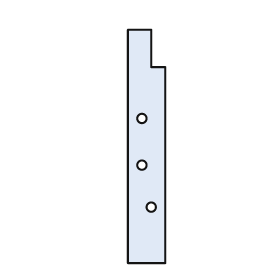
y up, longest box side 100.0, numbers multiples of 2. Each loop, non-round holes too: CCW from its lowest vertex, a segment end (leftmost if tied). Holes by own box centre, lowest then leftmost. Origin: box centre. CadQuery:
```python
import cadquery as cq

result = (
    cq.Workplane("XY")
    .moveTo(-8.0, -50.0)
    .lineTo(8.0, -50.0)
    .lineTo(8.0, 34.0)
    .lineTo(2.0, 34.0)
    .lineTo(2.0, 50.0)
    .lineTo(-8.0, 50.0)
    .close()
    .moveTo(2.0, -26.0)
    .circle(2.0)
    .moveTo(-2.0, -8.0)
    .circle(2.0)
    .moveTo(-2.0, 12.0)
    .circle(2.0)
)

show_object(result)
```